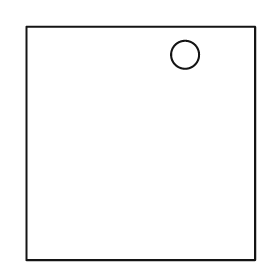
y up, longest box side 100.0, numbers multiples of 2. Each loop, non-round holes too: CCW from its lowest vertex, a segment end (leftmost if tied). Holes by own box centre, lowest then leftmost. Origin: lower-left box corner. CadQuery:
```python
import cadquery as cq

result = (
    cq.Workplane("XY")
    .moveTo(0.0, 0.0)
    .lineTo(98.0, 0.0)
    .lineTo(98.0, 100.0)
    .lineTo(0.0, 100.0)
    .close()
    .moveTo(68.0, 88.0)
    .circle(6.0)
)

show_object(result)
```